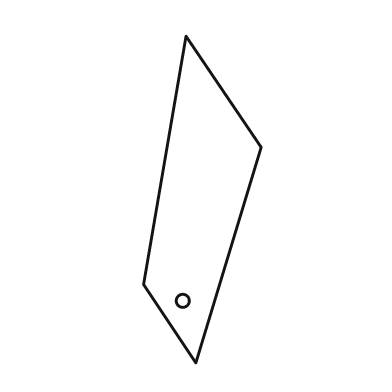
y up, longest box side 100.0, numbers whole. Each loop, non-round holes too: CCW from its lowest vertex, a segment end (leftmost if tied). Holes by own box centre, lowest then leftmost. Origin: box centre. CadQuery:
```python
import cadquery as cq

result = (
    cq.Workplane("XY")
    .moveTo(-2.0, -50.0)
    .lineTo(18.0, 16.0)
    .lineTo(-5.0, 50.0)
    .lineTo(-18.0, -26.0)
    .close()
    .moveTo(-6.0, -31.0)
    .circle(2.0)
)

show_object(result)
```